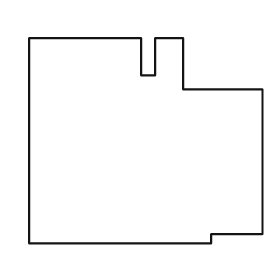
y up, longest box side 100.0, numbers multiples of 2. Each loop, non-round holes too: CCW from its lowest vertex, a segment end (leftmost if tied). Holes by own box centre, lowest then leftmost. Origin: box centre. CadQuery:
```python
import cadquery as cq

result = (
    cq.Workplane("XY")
    .moveTo(-50.0, -44.0)
    .lineTo(28.0, -44.0)
    .lineTo(28.0, -40.0)
    .lineTo(50.0, -40.0)
    .lineTo(50.0, 22.0)
    .lineTo(16.0, 22.0)
    .lineTo(16.0, 44.0)
    .lineTo(4.0, 44.0)
    .lineTo(4.0, 28.0)
    .lineTo(-2.0, 28.0)
    .lineTo(-2.0, 44.0)
    .lineTo(-50.0, 44.0)
    .close()
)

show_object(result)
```